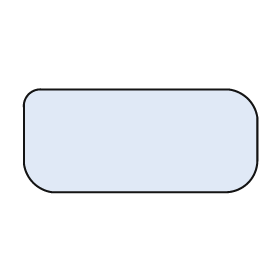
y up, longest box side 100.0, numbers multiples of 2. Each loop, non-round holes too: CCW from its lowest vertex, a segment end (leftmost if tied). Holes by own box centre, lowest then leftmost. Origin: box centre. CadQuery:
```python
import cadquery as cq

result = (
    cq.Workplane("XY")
    .moveTo(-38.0, -22.0)
    .lineTo(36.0, -22.0)
    .threePointArc((46.0, -18.0), (50.0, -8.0))
    .lineTo(50.0, 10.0)
    .threePointArc((46.0, 18.0), (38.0, 22.0))
    .lineTo(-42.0, 22.0)
    .threePointArc((-48.0, 20.0), (-50.0, 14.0))
    .lineTo(-50.0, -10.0)
    .threePointArc((-46.0, -18.0), (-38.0, -22.0))
    .close()
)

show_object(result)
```